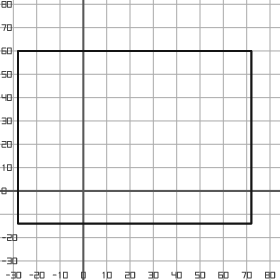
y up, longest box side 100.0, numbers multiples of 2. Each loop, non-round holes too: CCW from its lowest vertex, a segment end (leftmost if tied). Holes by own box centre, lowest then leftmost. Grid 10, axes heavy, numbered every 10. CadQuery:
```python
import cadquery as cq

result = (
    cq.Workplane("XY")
    .moveTo(-28.0, -14.0)
    .lineTo(72.0, -14.0)
    .lineTo(72.0, 60.0)
    .lineTo(-28.0, 60.0)
    .close()
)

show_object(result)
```